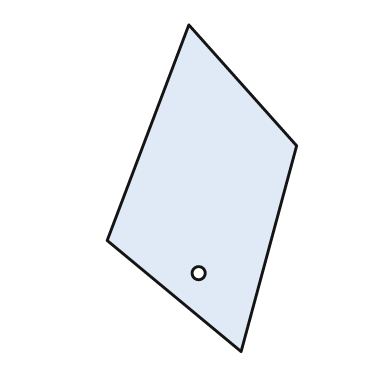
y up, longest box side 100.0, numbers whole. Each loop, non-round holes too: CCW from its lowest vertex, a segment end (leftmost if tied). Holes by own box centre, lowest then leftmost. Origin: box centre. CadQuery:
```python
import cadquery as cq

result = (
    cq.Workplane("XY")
    .moveTo(12.0, -50.0)
    .lineTo(29.0, 13.0)
    .lineTo(-4.0, 50.0)
    .lineTo(-29.0, -16.0)
    .close()
    .moveTo(-1.0, -26.0)
    .circle(2.0)
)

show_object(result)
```